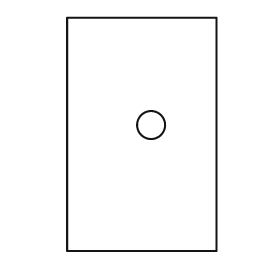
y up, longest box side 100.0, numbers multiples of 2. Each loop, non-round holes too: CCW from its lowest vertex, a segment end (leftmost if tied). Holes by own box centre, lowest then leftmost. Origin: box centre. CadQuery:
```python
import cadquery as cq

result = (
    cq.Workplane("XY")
    .moveTo(-32.0, -50.0)
    .lineTo(32.0, -50.0)
    .lineTo(32.0, 50.0)
    .lineTo(-32.0, 50.0)
    .close()
    .moveTo(4.0, 4.0)
    .circle(6.0)
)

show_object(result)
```